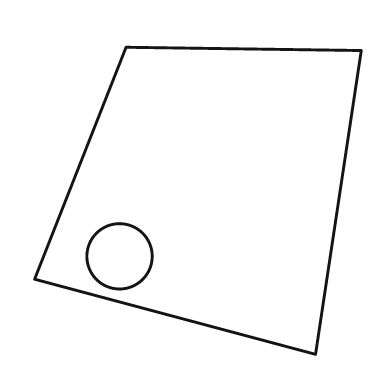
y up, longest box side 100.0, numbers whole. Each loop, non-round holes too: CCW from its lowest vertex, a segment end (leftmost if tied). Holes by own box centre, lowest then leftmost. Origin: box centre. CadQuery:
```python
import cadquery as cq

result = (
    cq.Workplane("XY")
    .moveTo(36.0, -47.0)
    .lineTo(50.0, 46.0)
    .lineTo(-22.0, 47.0)
    .lineTo(-50.0, -24.0)
    .close()
    .moveTo(-24.0, -17.0)
    .circle(10.0)
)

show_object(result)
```